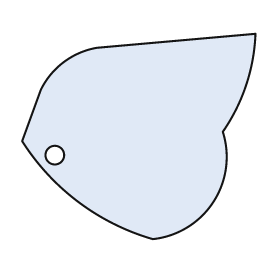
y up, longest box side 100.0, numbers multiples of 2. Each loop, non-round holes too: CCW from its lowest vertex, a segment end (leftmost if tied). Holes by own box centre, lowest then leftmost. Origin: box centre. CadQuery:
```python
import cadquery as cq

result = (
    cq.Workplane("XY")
    .moveTo(6.0, -44.0)
    .threePointArc((32.0, -28.0), (36.0, 2.0))
    .threePointArc((46.0, 22.0), (50.0, 44.0))
    .lineTo(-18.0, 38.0)
    .threePointArc((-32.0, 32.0), (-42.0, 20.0))
    .lineTo(-50.0, -2.0)
    .threePointArc((-26.0, -28.0), (6.0, -44.0))
    .close()
    .moveTo(-36.0, -8.0)
    .circle(4.0)
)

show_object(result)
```